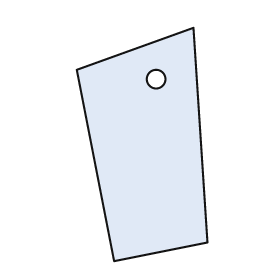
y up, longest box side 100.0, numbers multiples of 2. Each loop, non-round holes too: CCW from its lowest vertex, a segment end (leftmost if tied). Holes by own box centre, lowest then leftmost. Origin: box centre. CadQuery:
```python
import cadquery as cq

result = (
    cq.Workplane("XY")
    .moveTo(-12.0, -50.0)
    .lineTo(28.0, -42.0)
    .lineTo(22.0, 50.0)
    .lineTo(-28.0, 32.0)
    .close()
    .moveTo(6.0, 28.0)
    .circle(4.0)
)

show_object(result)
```